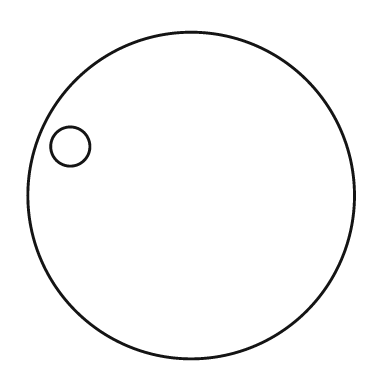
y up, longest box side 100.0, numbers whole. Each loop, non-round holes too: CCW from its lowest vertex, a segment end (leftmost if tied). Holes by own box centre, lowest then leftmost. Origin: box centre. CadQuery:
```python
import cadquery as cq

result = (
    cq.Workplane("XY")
    .moveTo(0.0, 0.0)
    .circle(50.0)
    .moveTo(-37.0, 15.0)
    .circle(6.0)
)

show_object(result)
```